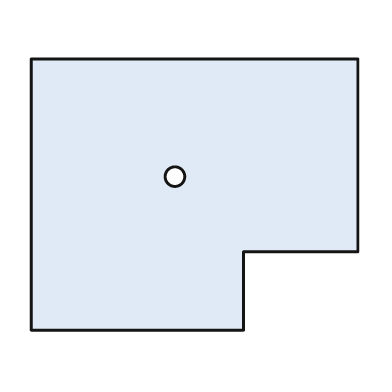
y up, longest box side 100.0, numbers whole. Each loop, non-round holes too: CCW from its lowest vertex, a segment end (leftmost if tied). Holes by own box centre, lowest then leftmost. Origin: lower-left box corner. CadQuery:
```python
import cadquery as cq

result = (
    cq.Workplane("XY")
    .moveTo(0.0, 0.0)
    .lineTo(65.0, 0.0)
    .lineTo(65.0, 24.0)
    .lineTo(100.0, 24.0)
    .lineTo(100.0, 83.0)
    .lineTo(0.0, 83.0)
    .close()
    .moveTo(44.0, 47.0)
    .circle(3.0)
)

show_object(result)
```